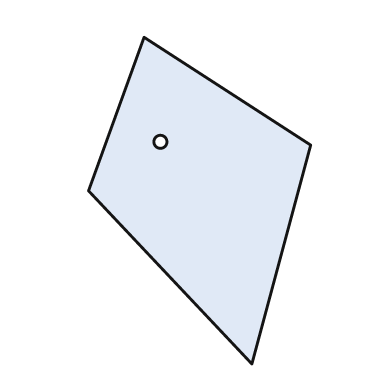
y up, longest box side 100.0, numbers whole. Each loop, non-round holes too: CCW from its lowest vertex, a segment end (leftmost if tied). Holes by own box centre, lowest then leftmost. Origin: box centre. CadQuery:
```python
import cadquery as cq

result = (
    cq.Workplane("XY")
    .moveTo(16.0, -50.0)
    .lineTo(34.0, 17.0)
    .lineTo(-17.0, 50.0)
    .lineTo(-34.0, 3.0)
    .close()
    .moveTo(-12.0, 18.0)
    .circle(2.0)
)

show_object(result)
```